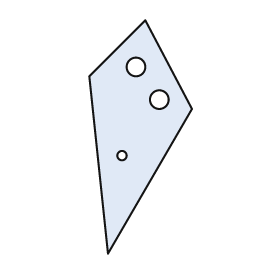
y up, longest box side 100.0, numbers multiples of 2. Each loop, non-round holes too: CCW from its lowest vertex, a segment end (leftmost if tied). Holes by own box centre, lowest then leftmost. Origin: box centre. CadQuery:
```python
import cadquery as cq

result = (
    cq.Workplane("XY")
    .moveTo(-14.0, -50.0)
    .lineTo(22.0, 12.0)
    .lineTo(2.0, 50.0)
    .lineTo(-22.0, 26.0)
    .close()
    .moveTo(-8.0, -8.0)
    .circle(2.0)
    .moveTo(8.0, 16.0)
    .circle(4.0)
    .moveTo(-2.0, 30.0)
    .circle(4.0)
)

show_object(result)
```